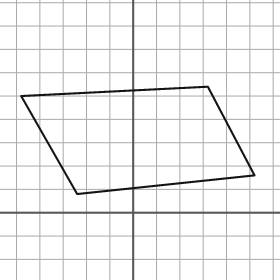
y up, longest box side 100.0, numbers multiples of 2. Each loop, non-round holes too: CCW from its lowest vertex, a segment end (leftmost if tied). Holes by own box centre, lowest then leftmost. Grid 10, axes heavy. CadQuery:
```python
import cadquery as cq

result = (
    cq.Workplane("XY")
    .moveTo(-24.0, 8.0)
    .lineTo(52.0, 16.0)
    .lineTo(32.0, 54.0)
    .lineTo(-48.0, 50.0)
    .close()
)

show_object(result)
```